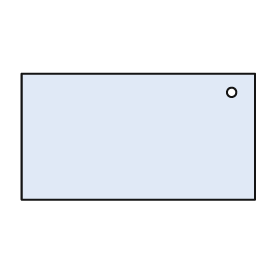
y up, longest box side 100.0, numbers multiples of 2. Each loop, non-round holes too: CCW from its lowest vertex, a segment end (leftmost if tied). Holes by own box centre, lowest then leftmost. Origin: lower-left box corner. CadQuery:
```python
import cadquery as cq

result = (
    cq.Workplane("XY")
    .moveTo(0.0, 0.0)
    .lineTo(100.0, 0.0)
    .lineTo(100.0, 54.0)
    .lineTo(0.0, 54.0)
    .close()
    .moveTo(90.0, 46.0)
    .circle(2.0)
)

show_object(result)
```